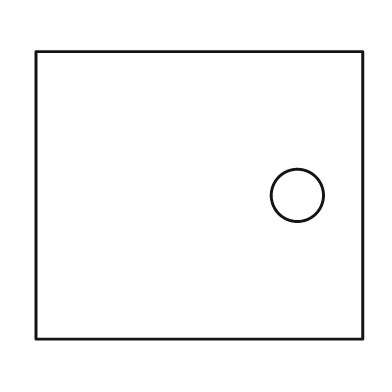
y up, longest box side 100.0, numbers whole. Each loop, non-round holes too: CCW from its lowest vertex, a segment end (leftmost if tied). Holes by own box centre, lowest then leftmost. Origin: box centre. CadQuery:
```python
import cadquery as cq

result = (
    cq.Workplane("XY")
    .moveTo(-50.0, -44.0)
    .lineTo(50.0, -44.0)
    .lineTo(50.0, 44.0)
    .lineTo(-50.0, 44.0)
    .close()
    .moveTo(30.0, 0.0)
    .circle(8.0)
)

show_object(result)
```